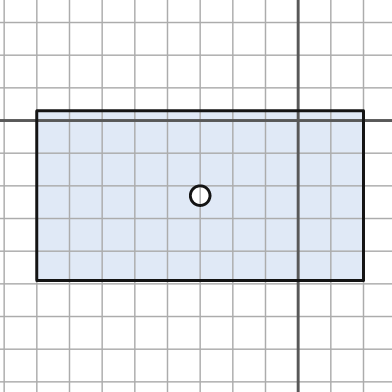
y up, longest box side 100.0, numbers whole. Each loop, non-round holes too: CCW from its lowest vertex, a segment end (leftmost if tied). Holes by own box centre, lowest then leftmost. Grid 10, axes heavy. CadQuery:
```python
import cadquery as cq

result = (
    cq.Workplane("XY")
    .moveTo(-80.0, -49.0)
    .lineTo(20.0, -49.0)
    .lineTo(20.0, 3.0)
    .lineTo(-80.0, 3.0)
    .close()
    .moveTo(-30.0, -23.0)
    .circle(3.0)
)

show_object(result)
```